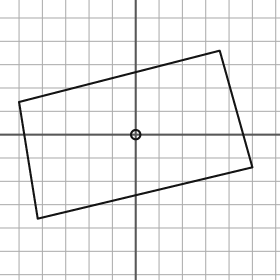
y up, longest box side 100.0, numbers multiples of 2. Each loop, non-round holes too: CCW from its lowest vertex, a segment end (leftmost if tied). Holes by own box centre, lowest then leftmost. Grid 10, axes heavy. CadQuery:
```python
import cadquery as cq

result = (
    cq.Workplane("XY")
    .moveTo(-42.0, -36.0)
    .lineTo(50.0, -14.0)
    .lineTo(36.0, 36.0)
    .lineTo(-50.0, 14.0)
    .close()
    .moveTo(0.0, 0.0)
    .circle(2.0)
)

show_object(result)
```